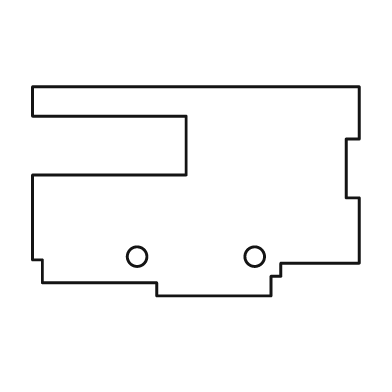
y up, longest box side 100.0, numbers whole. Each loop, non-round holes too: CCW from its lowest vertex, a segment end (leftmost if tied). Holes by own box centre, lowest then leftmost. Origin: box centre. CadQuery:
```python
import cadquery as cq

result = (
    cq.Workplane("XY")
    .moveTo(-12.0, -32.0)
    .lineTo(23.0, -32.0)
    .lineTo(23.0, -26.0)
    .lineTo(26.0, -26.0)
    .lineTo(26.0, -22.0)
    .lineTo(50.0, -22.0)
    .lineTo(50.0, -2.0)
    .lineTo(46.0, -2.0)
    .lineTo(46.0, 16.0)
    .lineTo(50.0, 16.0)
    .lineTo(50.0, 32.0)
    .lineTo(-50.0, 32.0)
    .lineTo(-50.0, 23.0)
    .lineTo(-3.0, 23.0)
    .lineTo(-3.0, 5.0)
    .lineTo(-50.0, 5.0)
    .lineTo(-50.0, -21.0)
    .lineTo(-47.0, -21.0)
    .lineTo(-47.0, -28.0)
    .lineTo(-12.0, -28.0)
    .close()
    .moveTo(-18.0, -20.0)
    .circle(3.0)
    .moveTo(18.0, -20.0)
    .circle(3.0)
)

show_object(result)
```